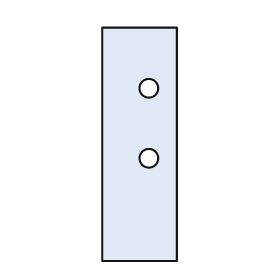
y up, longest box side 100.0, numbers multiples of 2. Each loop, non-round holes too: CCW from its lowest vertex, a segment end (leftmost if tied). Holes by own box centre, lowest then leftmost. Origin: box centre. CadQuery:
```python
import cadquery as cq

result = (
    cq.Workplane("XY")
    .moveTo(-16.0, -50.0)
    .lineTo(16.0, -50.0)
    .lineTo(16.0, 50.0)
    .lineTo(-16.0, 50.0)
    .close()
    .moveTo(4.0, -6.0)
    .circle(4.0)
    .moveTo(4.0, 24.0)
    .circle(4.0)
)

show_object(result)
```